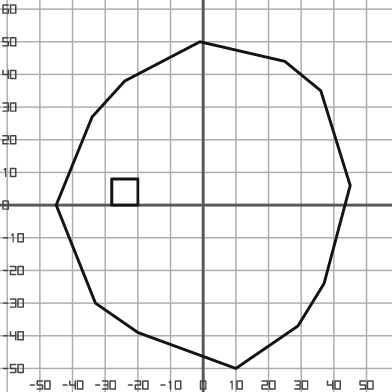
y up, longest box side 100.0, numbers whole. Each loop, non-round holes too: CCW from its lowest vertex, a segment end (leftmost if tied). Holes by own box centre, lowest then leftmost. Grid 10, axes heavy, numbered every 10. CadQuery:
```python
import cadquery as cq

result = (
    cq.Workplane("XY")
    .moveTo(10.0, -50.0)
    .lineTo(29.0, -37.0)
    .lineTo(37.0, -24.0)
    .lineTo(45.0, 6.0)
    .lineTo(36.0, 35.0)
    .lineTo(25.0, 44.0)
    .lineTo(-1.0, 50.0)
    .lineTo(-24.0, 38.0)
    .lineTo(-34.0, 27.0)
    .lineTo(-45.0, 0.0)
    .lineTo(-33.0, -30.0)
    .lineTo(-20.0, -39.0)
    .close()
    .moveTo(-28.0, 0.0)
    .lineTo(-20.0, 0.0)
    .lineTo(-20.0, 8.0)
    .lineTo(-28.0, 8.0)
    .close()
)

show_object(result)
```